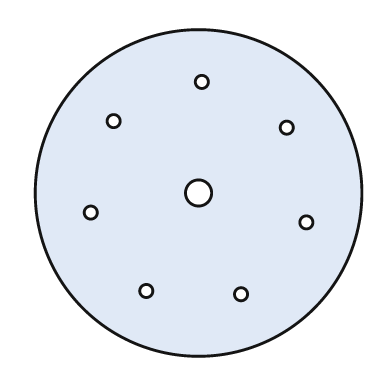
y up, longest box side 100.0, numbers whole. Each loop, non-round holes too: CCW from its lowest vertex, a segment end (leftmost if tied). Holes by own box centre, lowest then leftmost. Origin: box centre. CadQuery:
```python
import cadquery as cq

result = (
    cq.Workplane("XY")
    .moveTo(0.0, 0.0)
    .circle(50.0)
    .moveTo(13.0, -31.0)
    .circle(2.0)
    .moveTo(-16.0, -30.0)
    .circle(2.0)
    .moveTo(33.0, -9.0)
    .circle(2.0)
    .moveTo(-33.0, -6.0)
    .circle(2.0)
    .moveTo(0.0, 0.0)
    .circle(4.0)
    .moveTo(27.0, 20.0)
    .circle(2.0)
    .moveTo(-26.0, 22.0)
    .circle(2.0)
    .moveTo(1.0, 34.0)
    .circle(2.0)
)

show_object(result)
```